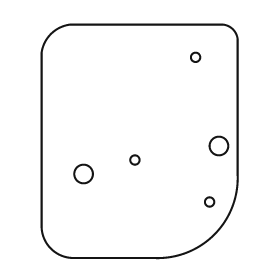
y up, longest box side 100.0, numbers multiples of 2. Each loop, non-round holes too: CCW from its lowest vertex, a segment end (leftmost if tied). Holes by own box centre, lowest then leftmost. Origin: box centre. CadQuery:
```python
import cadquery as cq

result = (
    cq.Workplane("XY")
    .moveTo(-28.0, -50.0)
    .lineTo(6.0, -50.0)
    .threePointArc((32.0, -40.0), (42.0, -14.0))
    .lineTo(42.0, 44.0)
    .threePointArc((40.0, 48.0), (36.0, 50.0))
    .lineTo(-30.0, 50.0)
    .threePointArc((-38.0, 46.0), (-42.0, 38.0))
    .lineTo(-42.0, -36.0)
    .threePointArc((-38.0, -46.0), (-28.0, -50.0))
    .close()
    .moveTo(30.0, -26.0)
    .circle(2.0)
    .moveTo(-24.0, -14.0)
    .circle(4.0)
    .moveTo(-2.0, -8.0)
    .circle(2.0)
    .moveTo(34.0, -2.0)
    .circle(4.0)
    .moveTo(24.0, 36.0)
    .circle(2.0)
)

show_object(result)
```